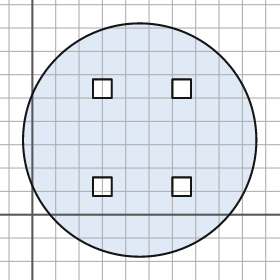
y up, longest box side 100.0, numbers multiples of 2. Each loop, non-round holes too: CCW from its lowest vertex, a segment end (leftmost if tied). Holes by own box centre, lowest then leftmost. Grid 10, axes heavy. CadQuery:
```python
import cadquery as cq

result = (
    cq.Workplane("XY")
    .moveTo(46.0, 32.0)
    .circle(50.0)
    .moveTo(26.0, 8.0)
    .lineTo(34.0, 8.0)
    .lineTo(34.0, 16.0)
    .lineTo(26.0, 16.0)
    .close()
    .moveTo(60.0, 8.0)
    .lineTo(68.0, 8.0)
    .lineTo(68.0, 16.0)
    .lineTo(60.0, 16.0)
    .close()
    .moveTo(26.0, 50.0)
    .lineTo(34.0, 50.0)
    .lineTo(34.0, 58.0)
    .lineTo(26.0, 58.0)
    .close()
    .moveTo(60.0, 50.0)
    .lineTo(68.0, 50.0)
    .lineTo(68.0, 58.0)
    .lineTo(60.0, 58.0)
    .close()
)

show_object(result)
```